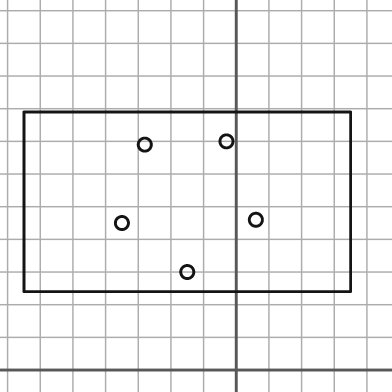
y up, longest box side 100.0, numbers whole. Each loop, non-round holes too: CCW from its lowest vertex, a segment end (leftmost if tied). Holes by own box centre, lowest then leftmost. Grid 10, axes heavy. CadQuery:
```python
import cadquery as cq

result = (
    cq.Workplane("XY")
    .moveTo(-65.0, 24.0)
    .lineTo(35.0, 24.0)
    .lineTo(35.0, 79.0)
    .lineTo(-65.0, 79.0)
    .close()
    .moveTo(-15.0, 30.0)
    .circle(2.0)
    .moveTo(-35.0, 45.0)
    .circle(2.0)
    .moveTo(6.0, 46.0)
    .circle(2.0)
    .moveTo(-28.0, 69.0)
    .circle(2.0)
    .moveTo(-3.0, 70.0)
    .circle(2.0)
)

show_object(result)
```